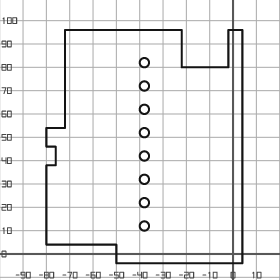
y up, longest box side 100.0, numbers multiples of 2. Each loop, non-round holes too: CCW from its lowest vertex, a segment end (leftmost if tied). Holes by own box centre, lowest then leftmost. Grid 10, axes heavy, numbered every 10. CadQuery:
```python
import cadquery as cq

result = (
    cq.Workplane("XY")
    .moveTo(-50.0, -4.0)
    .lineTo(4.0, -4.0)
    .lineTo(4.0, 96.0)
    .lineTo(-2.0, 96.0)
    .lineTo(-2.0, 80.0)
    .lineTo(-22.0, 80.0)
    .lineTo(-22.0, 96.0)
    .lineTo(-72.0, 96.0)
    .lineTo(-72.0, 54.0)
    .lineTo(-80.0, 54.0)
    .lineTo(-80.0, 46.0)
    .lineTo(-76.0, 46.0)
    .lineTo(-76.0, 38.0)
    .lineTo(-80.0, 38.0)
    .lineTo(-80.0, 4.0)
    .lineTo(-50.0, 4.0)
    .close()
    .moveTo(-38.0, 12.0)
    .circle(2.0)
    .moveTo(-38.0, 22.0)
    .circle(2.0)
    .moveTo(-38.0, 32.0)
    .circle(2.0)
    .moveTo(-38.0, 42.0)
    .circle(2.0)
    .moveTo(-38.0, 52.0)
    .circle(2.0)
    .moveTo(-38.0, 62.0)
    .circle(2.0)
    .moveTo(-38.0, 72.0)
    .circle(2.0)
    .moveTo(-38.0, 82.0)
    .circle(2.0)
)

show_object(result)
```